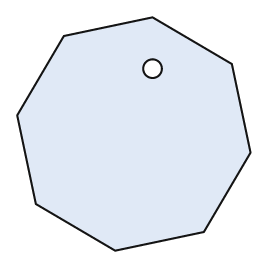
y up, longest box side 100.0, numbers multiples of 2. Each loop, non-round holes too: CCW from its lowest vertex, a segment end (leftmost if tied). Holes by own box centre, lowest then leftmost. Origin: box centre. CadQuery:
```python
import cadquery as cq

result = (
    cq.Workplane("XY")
    .moveTo(-8.0, -50.0)
    .lineTo(30.0, -42.0)
    .lineTo(50.0, -8.0)
    .lineTo(42.0, 30.0)
    .lineTo(8.0, 50.0)
    .lineTo(-30.0, 42.0)
    .lineTo(-50.0, 8.0)
    .lineTo(-42.0, -30.0)
    .close()
    .moveTo(8.0, 28.0)
    .circle(4.0)
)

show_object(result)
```